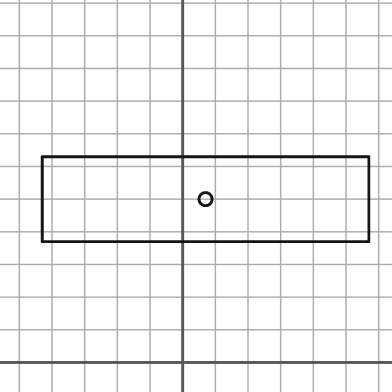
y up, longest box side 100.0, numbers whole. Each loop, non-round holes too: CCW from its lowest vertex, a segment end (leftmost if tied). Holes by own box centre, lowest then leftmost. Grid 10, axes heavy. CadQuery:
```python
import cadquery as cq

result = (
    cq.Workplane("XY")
    .moveTo(-43.0, 37.0)
    .lineTo(57.0, 37.0)
    .lineTo(57.0, 63.0)
    .lineTo(-43.0, 63.0)
    .close()
    .moveTo(7.0, 50.0)
    .circle(2.0)
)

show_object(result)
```